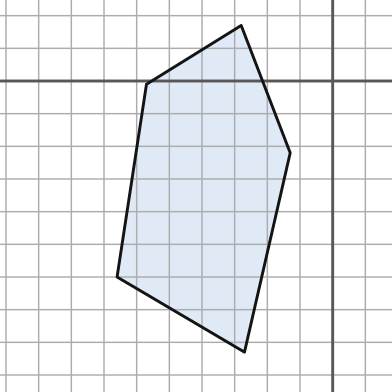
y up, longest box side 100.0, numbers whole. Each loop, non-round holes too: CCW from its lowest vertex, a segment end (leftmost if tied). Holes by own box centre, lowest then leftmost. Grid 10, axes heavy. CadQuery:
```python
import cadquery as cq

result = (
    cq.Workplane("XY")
    .moveTo(-27.0, -83.0)
    .lineTo(-13.0, -22.0)
    .lineTo(-28.0, 17.0)
    .lineTo(-57.0, -1.0)
    .lineTo(-66.0, -60.0)
    .close()
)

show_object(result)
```